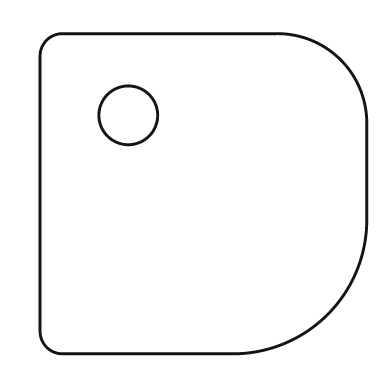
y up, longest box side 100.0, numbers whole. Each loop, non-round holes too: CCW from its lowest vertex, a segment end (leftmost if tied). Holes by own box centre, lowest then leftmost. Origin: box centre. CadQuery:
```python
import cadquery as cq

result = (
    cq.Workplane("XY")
    .moveTo(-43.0, -49.0)
    .lineTo(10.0, -49.0)
    .threePointArc((38.0, -37.0), (50.0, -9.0))
    .lineTo(50.0, 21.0)
    .threePointArc((42.0, 41.0), (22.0, 49.0))
    .lineTo(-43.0, 49.0)
    .threePointArc((-48.0, 47.0), (-50.0, 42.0))
    .lineTo(-50.0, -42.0)
    .threePointArc((-48.0, -47.0), (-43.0, -49.0))
    .close()
    .moveTo(-23.0, 24.0)
    .circle(9.0)
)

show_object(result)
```